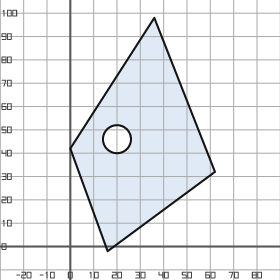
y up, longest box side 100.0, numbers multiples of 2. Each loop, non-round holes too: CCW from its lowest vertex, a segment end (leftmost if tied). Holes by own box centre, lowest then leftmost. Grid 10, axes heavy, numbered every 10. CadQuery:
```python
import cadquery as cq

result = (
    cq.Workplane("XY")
    .moveTo(16.0, -2.0)
    .lineTo(62.0, 32.0)
    .lineTo(36.0, 98.0)
    .lineTo(0.0, 42.0)
    .close()
    .moveTo(20.0, 46.0)
    .circle(6.0)
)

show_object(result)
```